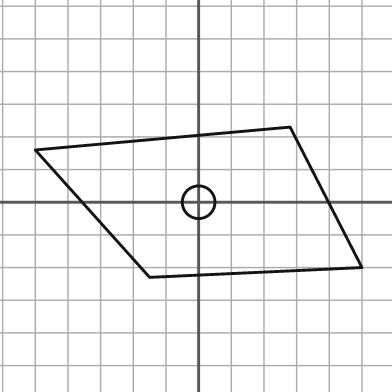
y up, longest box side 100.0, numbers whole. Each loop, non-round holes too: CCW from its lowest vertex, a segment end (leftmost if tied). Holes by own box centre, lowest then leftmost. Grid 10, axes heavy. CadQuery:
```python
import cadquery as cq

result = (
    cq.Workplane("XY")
    .moveTo(-15.0, -23.0)
    .lineTo(50.0, -20.0)
    .lineTo(28.0, 23.0)
    .lineTo(-50.0, 16.0)
    .close()
    .moveTo(0.0, 0.0)
    .circle(5.0)
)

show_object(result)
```